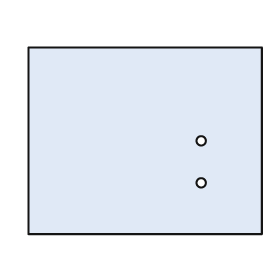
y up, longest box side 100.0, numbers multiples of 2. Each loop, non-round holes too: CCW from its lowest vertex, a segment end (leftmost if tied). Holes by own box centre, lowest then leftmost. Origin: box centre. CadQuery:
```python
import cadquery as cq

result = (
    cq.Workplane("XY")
    .moveTo(-50.0, -40.0)
    .lineTo(50.0, -40.0)
    .lineTo(50.0, 40.0)
    .lineTo(-50.0, 40.0)
    .close()
    .moveTo(24.0, -18.0)
    .circle(2.0)
    .moveTo(24.0, 0.0)
    .circle(2.0)
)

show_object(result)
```